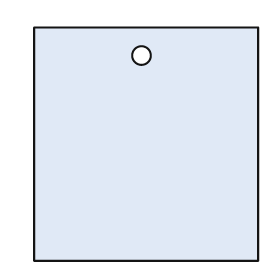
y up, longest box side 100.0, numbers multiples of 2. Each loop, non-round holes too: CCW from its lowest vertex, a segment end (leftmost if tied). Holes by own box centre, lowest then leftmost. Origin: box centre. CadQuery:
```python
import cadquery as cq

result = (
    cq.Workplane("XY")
    .moveTo(-48.0, -50.0)
    .lineTo(48.0, -50.0)
    .lineTo(48.0, 50.0)
    .lineTo(-48.0, 50.0)
    .close()
    .moveTo(-2.0, 38.0)
    .circle(4.0)
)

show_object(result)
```